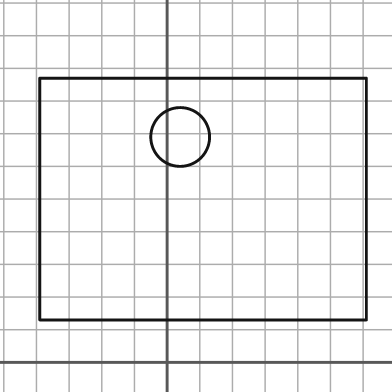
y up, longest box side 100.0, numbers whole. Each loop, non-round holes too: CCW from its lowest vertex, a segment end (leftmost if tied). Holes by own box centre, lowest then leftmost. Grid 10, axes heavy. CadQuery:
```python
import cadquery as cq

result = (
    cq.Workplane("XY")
    .moveTo(-39.0, 13.0)
    .lineTo(61.0, 13.0)
    .lineTo(61.0, 87.0)
    .lineTo(-39.0, 87.0)
    .close()
    .moveTo(4.0, 69.0)
    .circle(9.0)
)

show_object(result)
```